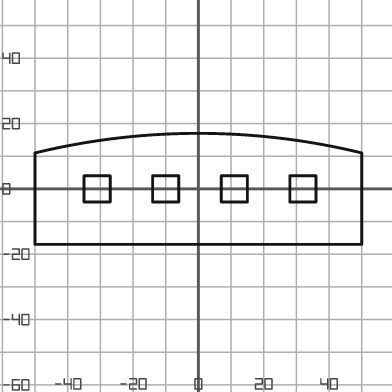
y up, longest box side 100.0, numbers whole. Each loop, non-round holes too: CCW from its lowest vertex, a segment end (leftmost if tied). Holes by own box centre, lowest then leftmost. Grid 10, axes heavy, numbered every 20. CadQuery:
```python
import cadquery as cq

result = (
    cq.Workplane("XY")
    .moveTo(-50.0, -17.0)
    .lineTo(50.0, -17.0)
    .lineTo(50.0, 11.0)
    .threePointArc((0.0, 17.0), (-50.0, 11.0))
    .close()
    .moveTo(-35.0, -4.0)
    .lineTo(-27.0, -4.0)
    .lineTo(-27.0, 4.0)
    .lineTo(-35.0, 4.0)
    .close()
    .moveTo(-14.0, -4.0)
    .lineTo(-6.0, -4.0)
    .lineTo(-6.0, 4.0)
    .lineTo(-14.0, 4.0)
    .close()
    .moveTo(7.0, -4.0)
    .lineTo(15.0, -4.0)
    .lineTo(15.0, 4.0)
    .lineTo(7.0, 4.0)
    .close()
    .moveTo(28.0, -4.0)
    .lineTo(36.0, -4.0)
    .lineTo(36.0, 4.0)
    .lineTo(28.0, 4.0)
    .close()
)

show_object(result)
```